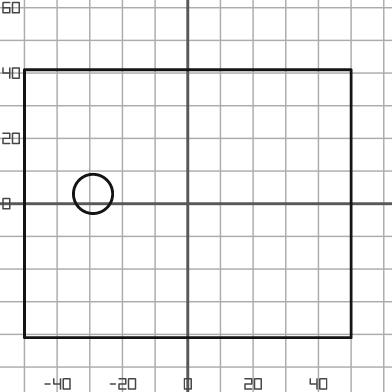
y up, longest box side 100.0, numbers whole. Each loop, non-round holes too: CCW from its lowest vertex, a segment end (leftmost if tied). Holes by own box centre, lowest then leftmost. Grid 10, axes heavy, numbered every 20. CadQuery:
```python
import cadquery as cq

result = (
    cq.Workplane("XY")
    .moveTo(-50.0, -41.0)
    .lineTo(50.0, -41.0)
    .lineTo(50.0, 41.0)
    .lineTo(-50.0, 41.0)
    .close()
    .moveTo(-29.0, 3.0)
    .circle(6.0)
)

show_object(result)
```